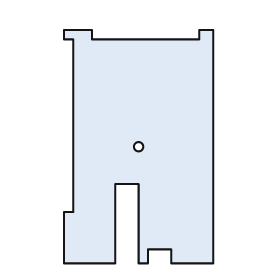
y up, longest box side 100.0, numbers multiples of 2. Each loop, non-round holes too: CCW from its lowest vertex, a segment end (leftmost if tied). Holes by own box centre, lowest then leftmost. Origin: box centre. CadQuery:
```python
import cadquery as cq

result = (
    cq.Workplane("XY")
    .moveTo(-32.0, -50.0)
    .lineTo(-10.0, -50.0)
    .lineTo(-10.0, -16.0)
    .lineTo(0.0, -16.0)
    .lineTo(0.0, -50.0)
    .lineTo(4.0, -50.0)
    .lineTo(4.0, -44.0)
    .lineTo(14.0, -44.0)
    .lineTo(14.0, -50.0)
    .lineTo(32.0, -50.0)
    .lineTo(32.0, 50.0)
    .lineTo(26.0, 50.0)
    .lineTo(26.0, 46.0)
    .lineTo(-20.0, 46.0)
    .lineTo(-20.0, 50.0)
    .lineTo(-32.0, 50.0)
    .lineTo(-32.0, 46.0)
    .lineTo(-28.0, 46.0)
    .lineTo(-28.0, -28.0)
    .lineTo(-32.0, -28.0)
    .close()
    .moveTo(0.0, 0.0)
    .circle(2.0)
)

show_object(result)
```